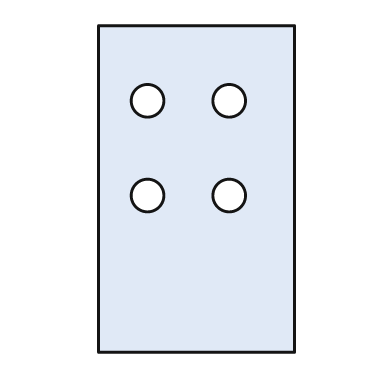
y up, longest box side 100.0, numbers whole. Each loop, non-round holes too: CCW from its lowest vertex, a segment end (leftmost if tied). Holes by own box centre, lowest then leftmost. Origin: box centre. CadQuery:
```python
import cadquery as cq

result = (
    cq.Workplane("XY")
    .moveTo(-30.0, -50.0)
    .lineTo(30.0, -50.0)
    .lineTo(30.0, 50.0)
    .lineTo(-30.0, 50.0)
    .close()
    .moveTo(-15.0, -2.0)
    .circle(5.0)
    .moveTo(10.0, -2.0)
    .circle(5.0)
    .moveTo(-15.0, 27.0)
    .circle(5.0)
    .moveTo(10.0, 27.0)
    .circle(5.0)
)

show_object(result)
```